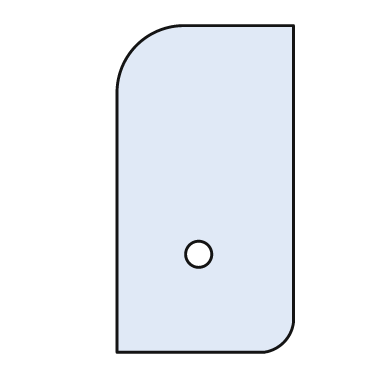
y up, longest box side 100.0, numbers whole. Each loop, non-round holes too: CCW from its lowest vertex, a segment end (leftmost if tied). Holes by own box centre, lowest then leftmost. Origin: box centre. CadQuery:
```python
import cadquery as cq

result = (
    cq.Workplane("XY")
    .moveTo(-27.0, -50.0)
    .lineTo(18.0, -50.0)
    .threePointArc((24.0, -47.0), (27.0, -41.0))
    .lineTo(27.0, 50.0)
    .lineTo(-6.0, 50.0)
    .threePointArc((-21.0, 44.0), (-27.0, 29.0))
    .close()
    .moveTo(-2.0, -20.0)
    .circle(4.0)
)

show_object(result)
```